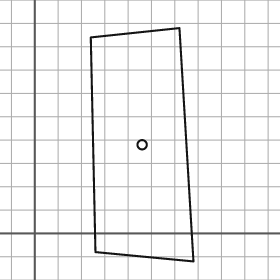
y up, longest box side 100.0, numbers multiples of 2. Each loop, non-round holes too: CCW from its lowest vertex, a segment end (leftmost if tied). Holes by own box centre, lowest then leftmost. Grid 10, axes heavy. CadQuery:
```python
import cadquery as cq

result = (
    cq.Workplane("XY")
    .moveTo(68.0, -12.0)
    .lineTo(62.0, 88.0)
    .lineTo(24.0, 84.0)
    .lineTo(26.0, -8.0)
    .close()
    .moveTo(46.0, 38.0)
    .circle(2.0)
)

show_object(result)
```